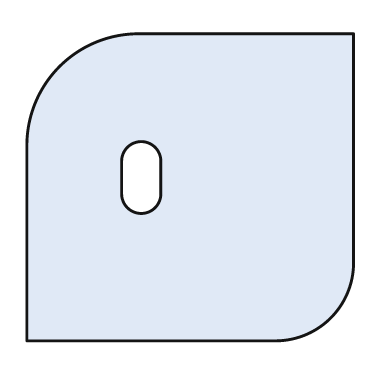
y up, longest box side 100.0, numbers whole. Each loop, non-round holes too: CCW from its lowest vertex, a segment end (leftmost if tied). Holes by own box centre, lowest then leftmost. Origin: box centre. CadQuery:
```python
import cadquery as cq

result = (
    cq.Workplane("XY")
    .moveTo(-50.0, -47.0)
    .lineTo(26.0, -47.0)
    .threePointArc((43.0, -40.0), (50.0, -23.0))
    .lineTo(50.0, 47.0)
    .lineTo(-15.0, 47.0)
    .threePointArc((-40.0, 37.0), (-50.0, 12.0))
    .close()
    .moveTo(-21.0, -2.0)
    .threePointArc((-15.0, -8.0), (-9.0, -2.0))
    .lineTo(-9.0, 8.0)
    .threePointArc((-15.0, 14.0), (-21.0, 8.0))
    .close()
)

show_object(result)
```